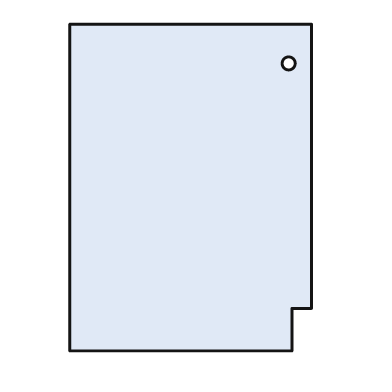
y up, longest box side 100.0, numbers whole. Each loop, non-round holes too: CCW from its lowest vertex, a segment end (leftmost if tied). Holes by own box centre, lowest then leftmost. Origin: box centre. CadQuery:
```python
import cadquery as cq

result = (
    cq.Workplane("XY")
    .moveTo(-37.0, -50.0)
    .lineTo(31.0, -50.0)
    .lineTo(31.0, -37.0)
    .lineTo(37.0, -37.0)
    .lineTo(37.0, 50.0)
    .lineTo(-37.0, 50.0)
    .close()
    .moveTo(30.0, 38.0)
    .circle(2.0)
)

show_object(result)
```